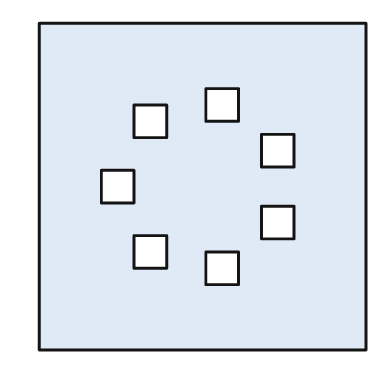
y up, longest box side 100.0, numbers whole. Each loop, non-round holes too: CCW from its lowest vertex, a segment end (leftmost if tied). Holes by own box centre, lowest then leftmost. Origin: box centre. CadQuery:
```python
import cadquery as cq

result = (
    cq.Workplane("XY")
    .moveTo(-50.0, -50.0)
    .lineTo(50.0, -50.0)
    .lineTo(50.0, 50.0)
    .lineTo(-50.0, 50.0)
    .close()
    .moveTo(1.0, -30.0)
    .lineTo(11.0, -30.0)
    .lineTo(11.0, -20.0)
    .lineTo(1.0, -20.0)
    .close()
    .moveTo(-21.0, -25.0)
    .lineTo(-11.0, -25.0)
    .lineTo(-11.0, -15.0)
    .lineTo(-21.0, -15.0)
    .close()
    .moveTo(18.0, -16.0)
    .lineTo(28.0, -16.0)
    .lineTo(28.0, -6.0)
    .lineTo(18.0, -6.0)
    .close()
    .moveTo(-31.0, -5.0)
    .lineTo(-21.0, -5.0)
    .lineTo(-21.0, 5.0)
    .lineTo(-31.0, 5.0)
    .close()
    .moveTo(18.0, 6.0)
    .lineTo(28.0, 6.0)
    .lineTo(28.0, 16.0)
    .lineTo(18.0, 16.0)
    .close()
    .moveTo(-21.0, 15.0)
    .lineTo(-11.0, 15.0)
    .lineTo(-11.0, 25.0)
    .lineTo(-21.0, 25.0)
    .close()
    .moveTo(1.0, 20.0)
    .lineTo(11.0, 20.0)
    .lineTo(11.0, 30.0)
    .lineTo(1.0, 30.0)
    .close()
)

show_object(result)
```